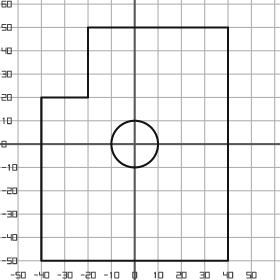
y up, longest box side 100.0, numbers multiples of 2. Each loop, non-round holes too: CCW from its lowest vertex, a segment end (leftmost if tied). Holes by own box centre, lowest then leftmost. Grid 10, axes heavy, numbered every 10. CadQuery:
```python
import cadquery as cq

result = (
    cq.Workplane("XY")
    .moveTo(-40.0, -50.0)
    .lineTo(40.0, -50.0)
    .lineTo(40.0, 50.0)
    .lineTo(-20.0, 50.0)
    .lineTo(-20.0, 20.0)
    .lineTo(-40.0, 20.0)
    .close()
    .moveTo(0.0, 0.0)
    .circle(10.0)
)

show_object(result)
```